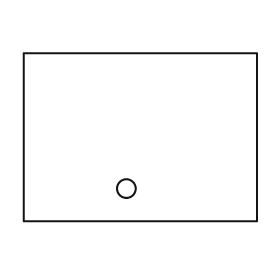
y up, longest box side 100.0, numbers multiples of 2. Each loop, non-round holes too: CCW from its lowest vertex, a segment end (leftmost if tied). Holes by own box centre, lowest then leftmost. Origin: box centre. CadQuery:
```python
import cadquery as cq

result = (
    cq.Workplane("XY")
    .moveTo(-50.0, -36.0)
    .lineTo(50.0, -36.0)
    .lineTo(50.0, 36.0)
    .lineTo(-50.0, 36.0)
    .close()
    .moveTo(-6.0, -22.0)
    .circle(4.0)
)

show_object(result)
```